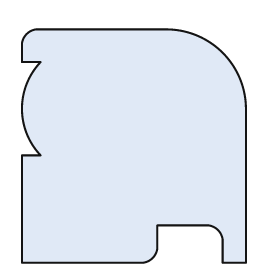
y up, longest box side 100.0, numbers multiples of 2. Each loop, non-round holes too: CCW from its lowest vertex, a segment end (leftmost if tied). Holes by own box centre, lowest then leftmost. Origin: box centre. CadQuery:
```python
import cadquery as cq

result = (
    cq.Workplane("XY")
    .moveTo(-48.0, -50.0)
    .lineTo(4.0, -50.0)
    .threePointArc((8.0, -48.0), (10.0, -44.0))
    .lineTo(10.0, -34.0)
    .lineTo(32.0, -34.0)
    .threePointArc((36.0, -36.0), (38.0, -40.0))
    .lineTo(38.0, -50.0)
    .lineTo(48.0, -50.0)
    .lineTo(48.0, 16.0)
    .threePointArc((38.0, 40.0), (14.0, 50.0))
    .lineTo(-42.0, 50.0)
    .threePointArc((-46.0, 48.0), (-48.0, 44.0))
    .lineTo(-48.0, 36.0)
    .lineTo(-40.0, 36.0)
    .threePointArc((-48.0, 16.0), (-40.0, -4.0))
    .lineTo(-48.0, -4.0)
    .close()
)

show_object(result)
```